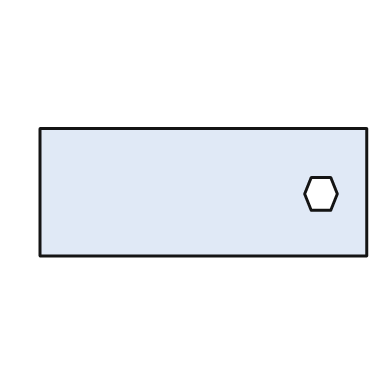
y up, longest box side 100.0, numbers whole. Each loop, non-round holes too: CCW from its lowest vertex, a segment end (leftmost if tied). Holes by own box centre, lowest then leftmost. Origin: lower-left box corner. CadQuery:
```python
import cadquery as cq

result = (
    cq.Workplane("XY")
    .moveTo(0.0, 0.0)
    .lineTo(100.0, 0.0)
    .lineTo(100.0, 39.0)
    .lineTo(0.0, 39.0)
    .close()
    .moveTo(83.0, 14.0)
    .lineTo(89.0, 14.0)
    .lineTo(91.0, 19.0)
    .lineTo(89.0, 24.0)
    .lineTo(83.0, 24.0)
    .lineTo(81.0, 19.0)
    .close()
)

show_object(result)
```